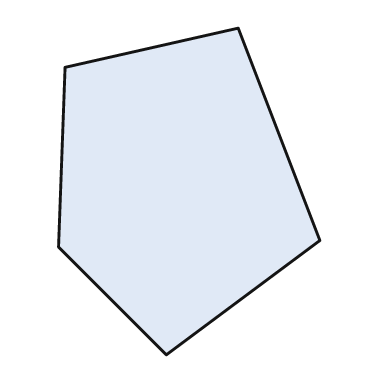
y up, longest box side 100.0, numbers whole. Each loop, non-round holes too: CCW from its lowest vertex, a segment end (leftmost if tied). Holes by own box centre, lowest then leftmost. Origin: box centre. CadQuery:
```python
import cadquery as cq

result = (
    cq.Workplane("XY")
    .moveTo(-7.0, -50.0)
    .lineTo(40.0, -15.0)
    .lineTo(15.0, 50.0)
    .lineTo(-38.0, 38.0)
    .lineTo(-40.0, -17.0)
    .close()
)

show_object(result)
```